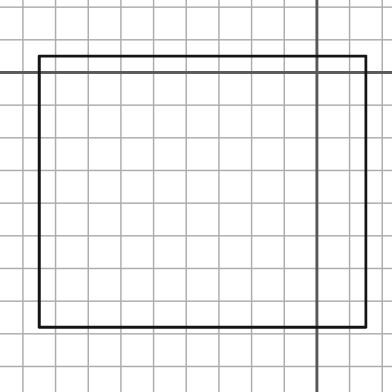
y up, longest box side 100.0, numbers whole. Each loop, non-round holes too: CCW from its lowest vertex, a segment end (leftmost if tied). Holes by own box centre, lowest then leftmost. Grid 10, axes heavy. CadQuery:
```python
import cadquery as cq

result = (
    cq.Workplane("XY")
    .moveTo(-85.0, -78.0)
    .lineTo(15.0, -78.0)
    .lineTo(15.0, 5.0)
    .lineTo(-85.0, 5.0)
    .close()
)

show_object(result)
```